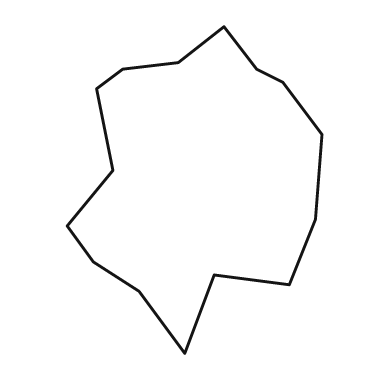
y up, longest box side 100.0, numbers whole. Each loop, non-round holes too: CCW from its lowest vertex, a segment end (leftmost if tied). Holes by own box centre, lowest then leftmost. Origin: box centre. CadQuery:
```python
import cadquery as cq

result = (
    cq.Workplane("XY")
    .moveTo(-3.0, -50.0)
    .lineTo(6.0, -26.0)
    .lineTo(29.0, -29.0)
    .lineTo(37.0, -9.0)
    .lineTo(39.0, 17.0)
    .lineTo(27.0, 33.0)
    .lineTo(19.0, 37.0)
    .lineTo(9.0, 50.0)
    .lineTo(-5.0, 39.0)
    .lineTo(-22.0, 37.0)
    .lineTo(-30.0, 31.0)
    .lineTo(-25.0, 6.0)
    .lineTo(-39.0, -11.0)
    .lineTo(-31.0, -22.0)
    .lineTo(-17.0, -31.0)
    .close()
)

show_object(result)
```